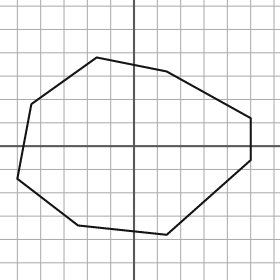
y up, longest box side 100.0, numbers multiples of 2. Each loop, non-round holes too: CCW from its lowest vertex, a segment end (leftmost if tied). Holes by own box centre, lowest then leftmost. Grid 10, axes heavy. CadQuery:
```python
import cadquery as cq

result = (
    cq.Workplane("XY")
    .moveTo(14.0, -38.0)
    .lineTo(50.0, -6.0)
    .lineTo(50.0, 12.0)
    .lineTo(14.0, 32.0)
    .lineTo(-16.0, 38.0)
    .lineTo(-44.0, 18.0)
    .lineTo(-50.0, -14.0)
    .lineTo(-24.0, -34.0)
    .close()
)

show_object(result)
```